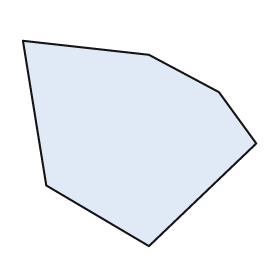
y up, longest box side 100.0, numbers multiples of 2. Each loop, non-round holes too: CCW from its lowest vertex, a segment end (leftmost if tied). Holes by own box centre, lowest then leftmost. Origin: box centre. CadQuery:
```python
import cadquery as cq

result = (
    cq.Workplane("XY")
    .moveTo(4.0, -44.0)
    .lineTo(50.0, 0.0)
    .lineTo(34.0, 22.0)
    .lineTo(4.0, 38.0)
    .lineTo(-50.0, 44.0)
    .lineTo(-40.0, -18.0)
    .close()
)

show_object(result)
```